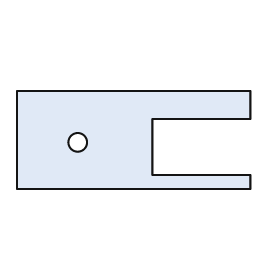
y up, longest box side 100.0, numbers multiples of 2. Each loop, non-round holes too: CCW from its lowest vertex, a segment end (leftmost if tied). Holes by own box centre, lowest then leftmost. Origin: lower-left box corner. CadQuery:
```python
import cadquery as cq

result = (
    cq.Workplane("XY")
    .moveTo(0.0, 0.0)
    .lineTo(100.0, 0.0)
    .lineTo(100.0, 6.0)
    .lineTo(58.0, 6.0)
    .lineTo(58.0, 30.0)
    .lineTo(100.0, 30.0)
    .lineTo(100.0, 42.0)
    .lineTo(0.0, 42.0)
    .close()
    .moveTo(26.0, 20.0)
    .circle(4.0)
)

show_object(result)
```